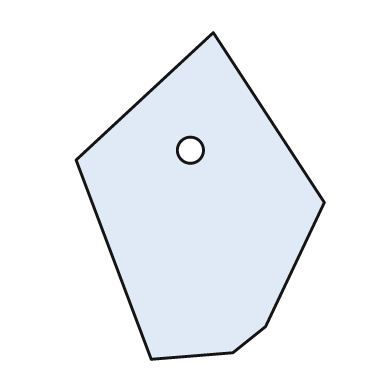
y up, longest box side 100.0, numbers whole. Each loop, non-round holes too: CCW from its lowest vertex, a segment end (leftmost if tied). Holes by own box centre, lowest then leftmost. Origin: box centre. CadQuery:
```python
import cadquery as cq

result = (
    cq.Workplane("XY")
    .moveTo(-15.0, -50.0)
    .lineTo(10.0, -48.0)
    .lineTo(20.0, -40.0)
    .lineTo(38.0, -2.0)
    .lineTo(4.0, 50.0)
    .lineTo(-38.0, 11.0)
    .close()
    .moveTo(-3.0, 14.0)
    .circle(4.0)
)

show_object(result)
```